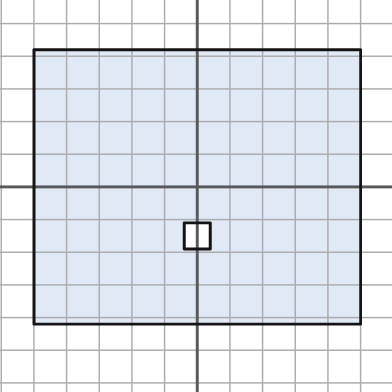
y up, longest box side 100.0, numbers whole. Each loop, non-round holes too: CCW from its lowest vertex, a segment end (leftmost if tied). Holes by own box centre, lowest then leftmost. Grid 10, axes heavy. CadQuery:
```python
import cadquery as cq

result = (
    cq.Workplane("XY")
    .moveTo(-50.0, -42.0)
    .lineTo(50.0, -42.0)
    .lineTo(50.0, 42.0)
    .lineTo(-50.0, 42.0)
    .close()
    .moveTo(-4.0, -19.0)
    .lineTo(4.0, -19.0)
    .lineTo(4.0, -11.0)
    .lineTo(-4.0, -11.0)
    .close()
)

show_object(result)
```